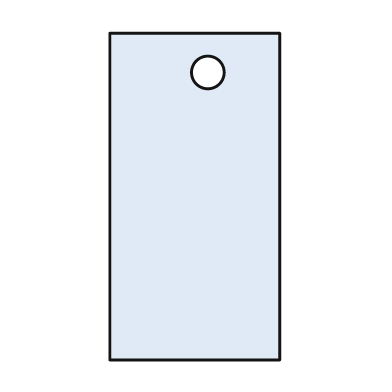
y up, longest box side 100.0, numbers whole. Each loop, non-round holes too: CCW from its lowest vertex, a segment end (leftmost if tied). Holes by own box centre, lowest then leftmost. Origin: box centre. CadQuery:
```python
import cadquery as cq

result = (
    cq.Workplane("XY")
    .moveTo(-26.0, -50.0)
    .lineTo(26.0, -50.0)
    .lineTo(26.0, 50.0)
    .lineTo(-26.0, 50.0)
    .close()
    .moveTo(4.0, 38.0)
    .circle(5.0)
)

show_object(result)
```